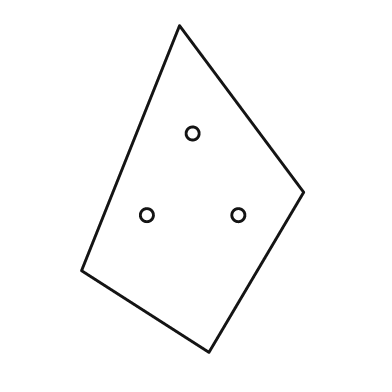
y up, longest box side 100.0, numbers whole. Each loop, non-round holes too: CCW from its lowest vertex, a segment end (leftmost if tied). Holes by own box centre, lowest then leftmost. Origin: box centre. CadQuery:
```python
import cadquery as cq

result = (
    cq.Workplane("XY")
    .moveTo(5.0, -50.0)
    .lineTo(34.0, -1.0)
    .lineTo(-4.0, 50.0)
    .lineTo(-34.0, -25.0)
    .close()
    .moveTo(-14.0, -8.0)
    .circle(2.0)
    .moveTo(14.0, -8.0)
    .circle(2.0)
    .moveTo(0.0, 17.0)
    .circle(2.0)
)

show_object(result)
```